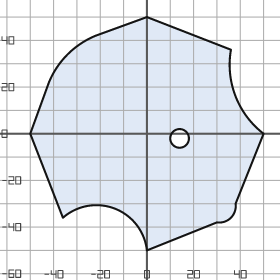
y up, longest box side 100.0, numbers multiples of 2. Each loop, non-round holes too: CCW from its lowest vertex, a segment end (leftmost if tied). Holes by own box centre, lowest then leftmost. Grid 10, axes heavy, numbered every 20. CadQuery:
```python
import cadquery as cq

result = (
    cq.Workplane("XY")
    .moveTo(0.0, -50.0)
    .lineTo(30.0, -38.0)
    .threePointArc((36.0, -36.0), (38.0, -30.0))
    .lineTo(50.0, 0.0)
    .threePointArc((38.0, 16.0), (36.0, 36.0))
    .lineTo(0.0, 50.0)
    .lineTo(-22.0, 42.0)
    .threePointArc((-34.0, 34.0), (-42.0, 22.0))
    .lineTo(-50.0, 0.0)
    .lineTo(-36.0, -36.0)
    .threePointArc((-14.0, -32.0), (0.0, -50.0))
    .close()
    .moveTo(14.0, -2.0)
    .circle(4.0)
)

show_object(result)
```